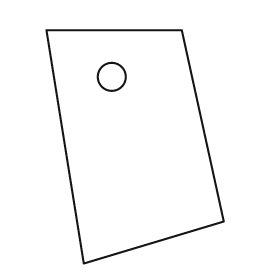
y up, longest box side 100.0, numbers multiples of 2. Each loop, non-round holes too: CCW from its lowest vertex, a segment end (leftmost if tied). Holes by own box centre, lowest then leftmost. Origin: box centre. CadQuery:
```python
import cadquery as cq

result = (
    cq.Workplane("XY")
    .moveTo(-22.0, -50.0)
    .lineTo(38.0, -32.0)
    .lineTo(20.0, 50.0)
    .lineTo(-38.0, 50.0)
    .close()
    .moveTo(-10.0, 30.0)
    .circle(6.0)
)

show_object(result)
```